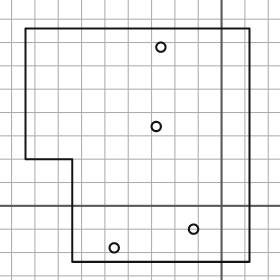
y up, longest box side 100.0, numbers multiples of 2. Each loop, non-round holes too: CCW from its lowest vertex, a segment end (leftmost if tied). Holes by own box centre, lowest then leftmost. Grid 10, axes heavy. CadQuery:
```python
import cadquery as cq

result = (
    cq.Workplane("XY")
    .moveTo(-64.0, -24.0)
    .lineTo(12.0, -24.0)
    .lineTo(12.0, 76.0)
    .lineTo(-84.0, 76.0)
    .lineTo(-84.0, 20.0)
    .lineTo(-64.0, 20.0)
    .close()
    .moveTo(-46.0, -18.0)
    .circle(2.0)
    .moveTo(-12.0, -10.0)
    .circle(2.0)
    .moveTo(-28.0, 34.0)
    .circle(2.0)
    .moveTo(-26.0, 68.0)
    .circle(2.0)
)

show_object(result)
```